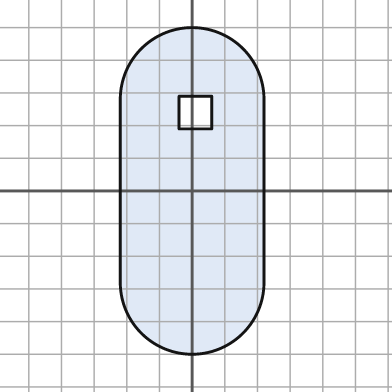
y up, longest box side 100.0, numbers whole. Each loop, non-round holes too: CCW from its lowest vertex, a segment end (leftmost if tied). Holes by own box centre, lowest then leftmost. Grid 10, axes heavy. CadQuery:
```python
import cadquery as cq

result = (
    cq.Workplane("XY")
    .moveTo(-22.0, -28.0)
    .threePointArc((0.0, -50.0), (22.0, -28.0))
    .lineTo(22.0, 28.0)
    .threePointArc((0.0, 50.0), (-22.0, 28.0))
    .close()
    .moveTo(-4.0, 19.0)
    .lineTo(6.0, 19.0)
    .lineTo(6.0, 29.0)
    .lineTo(-4.0, 29.0)
    .close()
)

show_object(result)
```